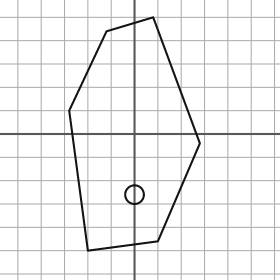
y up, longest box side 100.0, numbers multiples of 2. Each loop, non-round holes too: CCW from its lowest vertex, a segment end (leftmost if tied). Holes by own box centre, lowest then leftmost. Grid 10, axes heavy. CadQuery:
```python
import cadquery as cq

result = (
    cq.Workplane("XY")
    .moveTo(-20.0, -50.0)
    .lineTo(10.0, -46.0)
    .lineTo(28.0, -4.0)
    .lineTo(8.0, 50.0)
    .lineTo(-12.0, 44.0)
    .lineTo(-28.0, 10.0)
    .close()
    .moveTo(0.0, -26.0)
    .circle(4.0)
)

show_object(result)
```